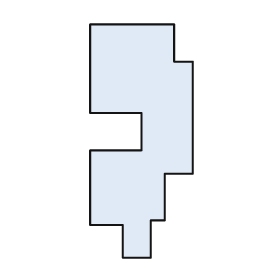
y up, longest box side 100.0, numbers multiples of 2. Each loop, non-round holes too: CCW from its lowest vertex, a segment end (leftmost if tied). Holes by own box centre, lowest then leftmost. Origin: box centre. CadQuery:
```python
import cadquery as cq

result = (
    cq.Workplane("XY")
    .moveTo(-8.0, -50.0)
    .lineTo(4.0, -50.0)
    .lineTo(4.0, -34.0)
    .lineTo(10.0, -34.0)
    .lineTo(10.0, -14.0)
    .lineTo(22.0, -14.0)
    .lineTo(22.0, 34.0)
    .lineTo(14.0, 34.0)
    .lineTo(14.0, 50.0)
    .lineTo(-22.0, 50.0)
    .lineTo(-22.0, 12.0)
    .lineTo(0.0, 12.0)
    .lineTo(0.0, -4.0)
    .lineTo(-22.0, -4.0)
    .lineTo(-22.0, -36.0)
    .lineTo(-8.0, -36.0)
    .close()
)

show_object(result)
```